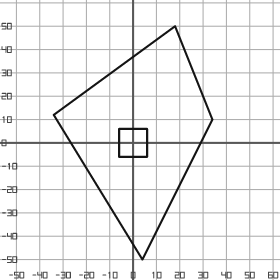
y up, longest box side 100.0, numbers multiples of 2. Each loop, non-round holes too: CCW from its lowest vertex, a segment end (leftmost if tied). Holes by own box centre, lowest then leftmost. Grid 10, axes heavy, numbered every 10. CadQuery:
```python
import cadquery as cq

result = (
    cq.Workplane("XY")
    .moveTo(4.0, -50.0)
    .lineTo(34.0, 10.0)
    .lineTo(18.0, 50.0)
    .lineTo(-34.0, 12.0)
    .close()
    .moveTo(-6.0, -6.0)
    .lineTo(6.0, -6.0)
    .lineTo(6.0, 6.0)
    .lineTo(-6.0, 6.0)
    .close()
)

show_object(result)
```